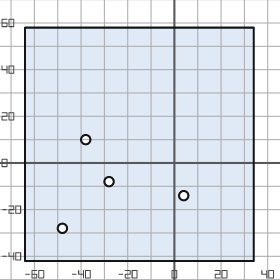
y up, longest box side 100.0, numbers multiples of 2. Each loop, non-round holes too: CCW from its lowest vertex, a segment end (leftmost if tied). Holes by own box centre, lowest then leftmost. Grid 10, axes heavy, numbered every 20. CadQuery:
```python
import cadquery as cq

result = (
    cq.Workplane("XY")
    .moveTo(-64.0, -42.0)
    .lineTo(34.0, -42.0)
    .lineTo(34.0, 58.0)
    .lineTo(-64.0, 58.0)
    .close()
    .moveTo(-48.0, -28.0)
    .circle(2.0)
    .moveTo(4.0, -14.0)
    .circle(2.0)
    .moveTo(-28.0, -8.0)
    .circle(2.0)
    .moveTo(-38.0, 10.0)
    .circle(2.0)
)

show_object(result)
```